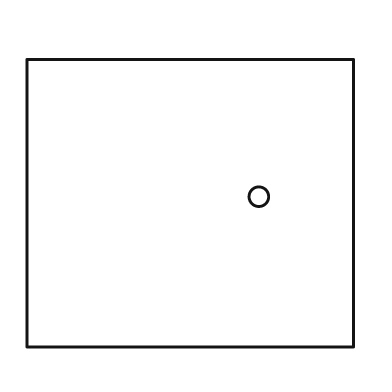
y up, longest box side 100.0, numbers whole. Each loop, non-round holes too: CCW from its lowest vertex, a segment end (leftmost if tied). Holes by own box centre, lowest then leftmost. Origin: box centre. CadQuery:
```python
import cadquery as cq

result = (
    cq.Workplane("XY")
    .moveTo(-50.0, -44.0)
    .lineTo(50.0, -44.0)
    .lineTo(50.0, 44.0)
    .lineTo(-50.0, 44.0)
    .close()
    .moveTo(21.0, 2.0)
    .circle(3.0)
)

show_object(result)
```